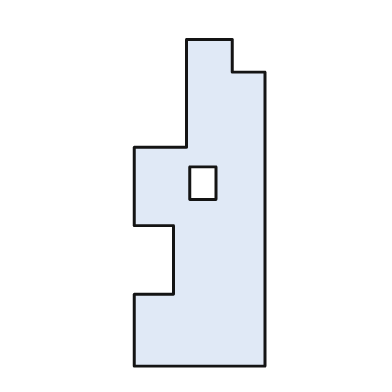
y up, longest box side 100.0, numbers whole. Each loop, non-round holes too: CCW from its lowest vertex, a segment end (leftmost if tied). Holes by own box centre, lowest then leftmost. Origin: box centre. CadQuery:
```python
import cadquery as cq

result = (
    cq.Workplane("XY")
    .moveTo(-20.0, -50.0)
    .lineTo(20.0, -50.0)
    .lineTo(20.0, 40.0)
    .lineTo(10.0, 40.0)
    .lineTo(10.0, 50.0)
    .lineTo(-4.0, 50.0)
    .lineTo(-4.0, 17.0)
    .lineTo(-20.0, 17.0)
    .lineTo(-20.0, -7.0)
    .lineTo(-8.0, -7.0)
    .lineTo(-8.0, -28.0)
    .lineTo(-20.0, -28.0)
    .close()
    .moveTo(-3.0, 1.0)
    .lineTo(5.0, 1.0)
    .lineTo(5.0, 11.0)
    .lineTo(-3.0, 11.0)
    .close()
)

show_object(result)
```